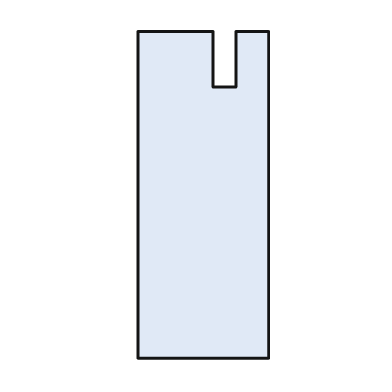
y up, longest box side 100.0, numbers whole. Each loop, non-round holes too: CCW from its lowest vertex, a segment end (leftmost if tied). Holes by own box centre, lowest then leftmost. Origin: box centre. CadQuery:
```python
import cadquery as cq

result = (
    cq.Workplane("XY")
    .moveTo(-20.0, -50.0)
    .lineTo(20.0, -50.0)
    .lineTo(20.0, 50.0)
    .lineTo(10.0, 50.0)
    .lineTo(10.0, 33.0)
    .lineTo(3.0, 33.0)
    .lineTo(3.0, 50.0)
    .lineTo(-20.0, 50.0)
    .close()
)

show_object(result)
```